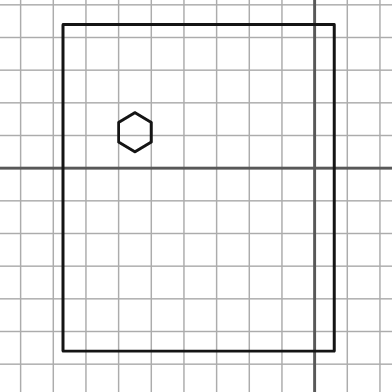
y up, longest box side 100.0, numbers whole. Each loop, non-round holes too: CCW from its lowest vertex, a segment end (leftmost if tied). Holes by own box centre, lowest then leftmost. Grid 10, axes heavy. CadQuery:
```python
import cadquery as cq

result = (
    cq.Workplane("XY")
    .moveTo(-77.0, -56.0)
    .lineTo(6.0, -56.0)
    .lineTo(6.0, 44.0)
    .lineTo(-77.0, 44.0)
    .close()
    .moveTo(-55.0, 5.0)
    .lineTo(-50.0, 8.0)
    .lineTo(-50.0, 14.0)
    .lineTo(-55.0, 17.0)
    .lineTo(-60.0, 14.0)
    .lineTo(-60.0, 8.0)
    .close()
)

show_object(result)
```